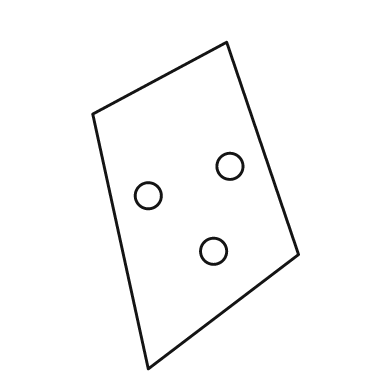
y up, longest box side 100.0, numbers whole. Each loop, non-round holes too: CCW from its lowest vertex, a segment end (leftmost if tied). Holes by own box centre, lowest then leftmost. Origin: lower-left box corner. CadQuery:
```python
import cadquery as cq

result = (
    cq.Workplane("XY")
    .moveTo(17.0, 0.0)
    .lineTo(63.0, 35.0)
    .lineTo(41.0, 100.0)
    .lineTo(0.0, 78.0)
    .close()
    .moveTo(37.0, 36.0)
    .circle(4.0)
    .moveTo(17.0, 53.0)
    .circle(4.0)
    .moveTo(42.0, 62.0)
    .circle(4.0)
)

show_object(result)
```